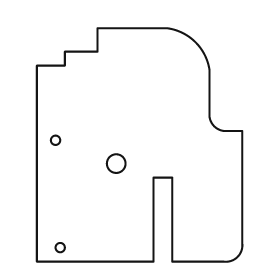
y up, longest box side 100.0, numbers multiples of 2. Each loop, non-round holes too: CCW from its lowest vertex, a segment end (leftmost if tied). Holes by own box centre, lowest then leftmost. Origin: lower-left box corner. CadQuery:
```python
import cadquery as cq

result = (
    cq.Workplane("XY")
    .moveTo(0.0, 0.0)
    .lineTo(50.0, 0.0)
    .lineTo(50.0, 36.0)
    .lineTo(58.0, 36.0)
    .lineTo(58.0, 0.0)
    .lineTo(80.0, 0.0)
    .threePointArc((86.0, 2.0), (88.0, 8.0))
    .lineTo(88.0, 56.0)
    .lineTo(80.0, 56.0)
    .threePointArc((76.0, 58.0), (74.0, 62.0))
    .lineTo(74.0, 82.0)
    .threePointArc((68.0, 94.0), (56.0, 100.0))
    .lineTo(26.0, 100.0)
    .lineTo(26.0, 90.0)
    .lineTo(12.0, 90.0)
    .lineTo(12.0, 84.0)
    .lineTo(0.0, 84.0)
    .close()
    .moveTo(10.0, 6.0)
    .circle(2.0)
    .moveTo(34.0, 42.0)
    .circle(4.0)
    .moveTo(8.0, 52.0)
    .circle(2.0)
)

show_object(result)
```